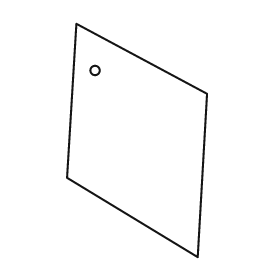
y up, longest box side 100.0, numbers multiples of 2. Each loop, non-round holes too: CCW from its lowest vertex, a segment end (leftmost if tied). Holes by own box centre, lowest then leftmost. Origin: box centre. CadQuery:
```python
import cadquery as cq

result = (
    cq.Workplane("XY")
    .moveTo(26.0, -50.0)
    .lineTo(30.0, 20.0)
    .lineTo(-26.0, 50.0)
    .lineTo(-30.0, -16.0)
    .close()
    .moveTo(-18.0, 30.0)
    .circle(2.0)
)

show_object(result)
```